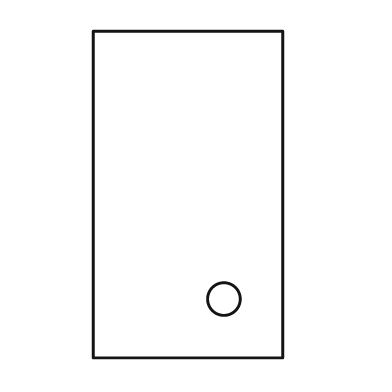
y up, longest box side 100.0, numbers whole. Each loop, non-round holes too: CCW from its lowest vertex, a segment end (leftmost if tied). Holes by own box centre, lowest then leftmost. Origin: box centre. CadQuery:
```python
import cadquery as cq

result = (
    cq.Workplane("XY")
    .moveTo(-29.0, -50.0)
    .lineTo(29.0, -50.0)
    .lineTo(29.0, 50.0)
    .lineTo(-29.0, 50.0)
    .close()
    .moveTo(11.0, -32.0)
    .circle(5.0)
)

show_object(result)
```